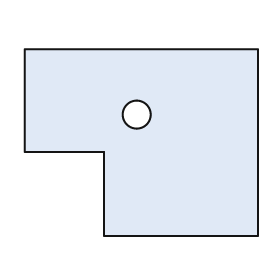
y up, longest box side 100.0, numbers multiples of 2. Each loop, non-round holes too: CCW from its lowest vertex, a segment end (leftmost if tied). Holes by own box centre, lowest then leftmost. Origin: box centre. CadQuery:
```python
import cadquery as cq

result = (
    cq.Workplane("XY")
    .moveTo(-16.0, -40.0)
    .lineTo(50.0, -40.0)
    .lineTo(50.0, 40.0)
    .lineTo(-50.0, 40.0)
    .lineTo(-50.0, -4.0)
    .lineTo(-16.0, -4.0)
    .close()
    .moveTo(-2.0, 12.0)
    .circle(6.0)
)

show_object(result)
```